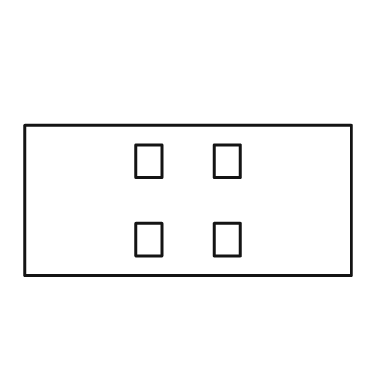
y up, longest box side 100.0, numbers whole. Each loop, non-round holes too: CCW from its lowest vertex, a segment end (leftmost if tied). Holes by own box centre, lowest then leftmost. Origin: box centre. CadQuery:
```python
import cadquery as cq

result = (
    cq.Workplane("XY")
    .moveTo(-50.0, -23.0)
    .lineTo(50.0, -23.0)
    .lineTo(50.0, 23.0)
    .lineTo(-50.0, 23.0)
    .close()
    .moveTo(-16.0, -17.0)
    .lineTo(-8.0, -17.0)
    .lineTo(-8.0, -7.0)
    .lineTo(-16.0, -7.0)
    .close()
    .moveTo(8.0, -17.0)
    .lineTo(16.0, -17.0)
    .lineTo(16.0, -7.0)
    .lineTo(8.0, -7.0)
    .close()
    .moveTo(-16.0, 7.0)
    .lineTo(-8.0, 7.0)
    .lineTo(-8.0, 17.0)
    .lineTo(-16.0, 17.0)
    .close()
    .moveTo(8.0, 7.0)
    .lineTo(16.0, 7.0)
    .lineTo(16.0, 17.0)
    .lineTo(8.0, 17.0)
    .close()
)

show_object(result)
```